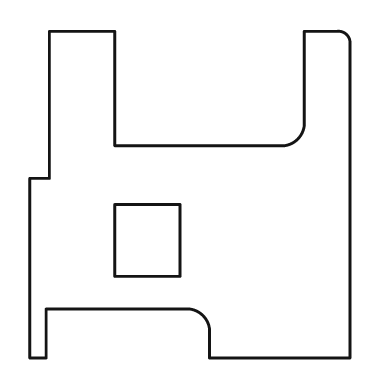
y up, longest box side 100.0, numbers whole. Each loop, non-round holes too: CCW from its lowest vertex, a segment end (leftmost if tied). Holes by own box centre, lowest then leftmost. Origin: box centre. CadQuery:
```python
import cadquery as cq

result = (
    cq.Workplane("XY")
    .moveTo(-49.0, -50.0)
    .lineTo(-44.0, -50.0)
    .lineTo(-44.0, -35.0)
    .lineTo(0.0, -35.0)
    .threePointArc((4.0, -37.0), (6.0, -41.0))
    .lineTo(6.0, -50.0)
    .lineTo(49.0, -50.0)
    .lineTo(49.0, 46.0)
    .threePointArc((48.0, 49.0), (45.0, 50.0))
    .lineTo(35.0, 50.0)
    .lineTo(35.0, 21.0)
    .threePointArc((33.0, 17.0), (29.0, 15.0))
    .lineTo(-23.0, 15.0)
    .lineTo(-23.0, 50.0)
    .lineTo(-43.0, 50.0)
    .lineTo(-43.0, 5.0)
    .lineTo(-49.0, 5.0)
    .close()
    .moveTo(-23.0, -25.0)
    .lineTo(-3.0, -25.0)
    .lineTo(-3.0, -3.0)
    .lineTo(-23.0, -3.0)
    .close()
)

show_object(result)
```